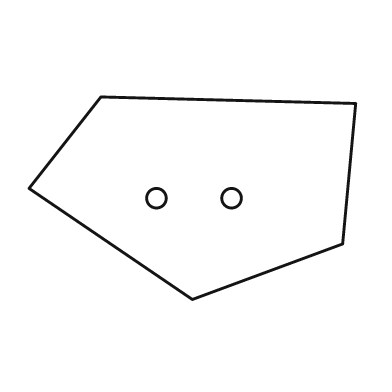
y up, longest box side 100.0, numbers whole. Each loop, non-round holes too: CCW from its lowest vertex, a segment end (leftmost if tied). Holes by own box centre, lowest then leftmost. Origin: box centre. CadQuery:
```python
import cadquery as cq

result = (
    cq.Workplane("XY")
    .moveTo(0.0, -31.0)
    .lineTo(46.0, -14.0)
    .lineTo(50.0, 29.0)
    .lineTo(-28.0, 31.0)
    .lineTo(-50.0, 3.0)
    .close()
    .moveTo(-11.0, 0.0)
    .circle(3.0)
    .moveTo(12.0, 0.0)
    .circle(3.0)
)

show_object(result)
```